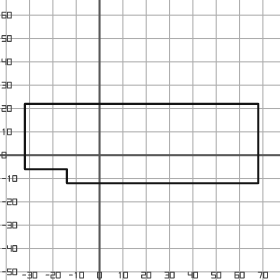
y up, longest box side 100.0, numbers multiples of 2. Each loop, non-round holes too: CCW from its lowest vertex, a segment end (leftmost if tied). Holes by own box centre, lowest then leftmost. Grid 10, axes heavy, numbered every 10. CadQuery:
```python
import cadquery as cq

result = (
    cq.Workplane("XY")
    .moveTo(-14.0, -12.0)
    .lineTo(68.0, -12.0)
    .lineTo(68.0, 22.0)
    .lineTo(-32.0, 22.0)
    .lineTo(-32.0, -6.0)
    .lineTo(-14.0, -6.0)
    .close()
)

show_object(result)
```